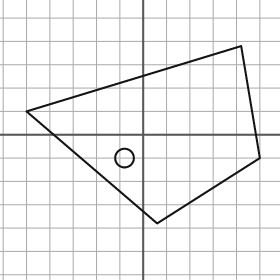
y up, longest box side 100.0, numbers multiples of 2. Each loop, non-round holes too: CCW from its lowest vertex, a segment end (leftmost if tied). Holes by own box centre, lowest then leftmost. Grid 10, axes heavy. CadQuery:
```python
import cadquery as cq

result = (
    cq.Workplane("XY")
    .moveTo(6.0, -38.0)
    .lineTo(50.0, -10.0)
    .lineTo(42.0, 38.0)
    .lineTo(-50.0, 10.0)
    .close()
    .moveTo(-8.0, -10.0)
    .circle(4.0)
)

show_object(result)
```